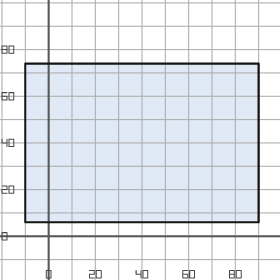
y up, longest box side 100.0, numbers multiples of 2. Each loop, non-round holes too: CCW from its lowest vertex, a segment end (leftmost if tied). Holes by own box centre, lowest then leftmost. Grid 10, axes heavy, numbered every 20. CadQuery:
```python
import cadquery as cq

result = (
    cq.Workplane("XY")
    .moveTo(-10.0, 6.0)
    .lineTo(90.0, 6.0)
    .lineTo(90.0, 74.0)
    .lineTo(-10.0, 74.0)
    .close()
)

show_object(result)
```